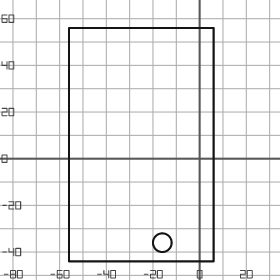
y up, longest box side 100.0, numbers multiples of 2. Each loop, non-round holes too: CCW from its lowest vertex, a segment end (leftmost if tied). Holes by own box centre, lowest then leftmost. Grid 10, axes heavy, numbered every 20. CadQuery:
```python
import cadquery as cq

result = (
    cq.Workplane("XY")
    .moveTo(-56.0, -44.0)
    .lineTo(6.0, -44.0)
    .lineTo(6.0, 56.0)
    .lineTo(-56.0, 56.0)
    .close()
    .moveTo(-16.0, -36.0)
    .circle(4.0)
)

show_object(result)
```